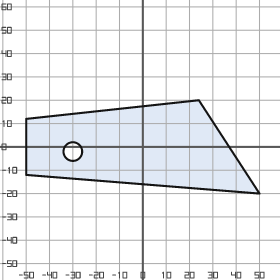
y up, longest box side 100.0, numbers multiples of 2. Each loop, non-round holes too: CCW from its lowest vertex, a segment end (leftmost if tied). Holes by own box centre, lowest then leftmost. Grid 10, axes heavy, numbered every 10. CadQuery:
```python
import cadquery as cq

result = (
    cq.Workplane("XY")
    .moveTo(50.0, -20.0)
    .lineTo(24.0, 20.0)
    .lineTo(-50.0, 12.0)
    .lineTo(-50.0, -12.0)
    .close()
    .moveTo(-30.0, -2.0)
    .circle(4.0)
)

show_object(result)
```